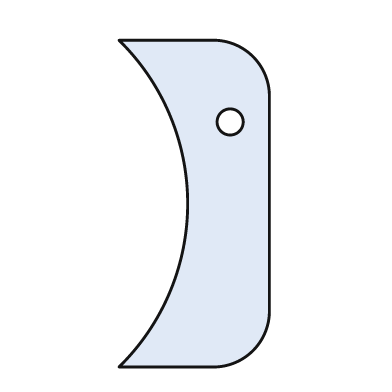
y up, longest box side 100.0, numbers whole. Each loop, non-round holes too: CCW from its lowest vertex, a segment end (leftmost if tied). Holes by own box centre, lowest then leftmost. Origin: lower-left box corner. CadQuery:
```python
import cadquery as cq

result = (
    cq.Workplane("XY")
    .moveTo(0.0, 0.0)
    .lineTo(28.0, 0.0)
    .threePointArc((41.0, 5.0), (46.0, 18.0))
    .lineTo(46.0, 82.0)
    .threePointArc((41.0, 95.0), (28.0, 100.0))
    .lineTo(0.0, 100.0)
    .threePointArc((21.0, 50.0), (0.0, 0.0))
    .close()
    .moveTo(34.0, 75.0)
    .circle(4.0)
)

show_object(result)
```